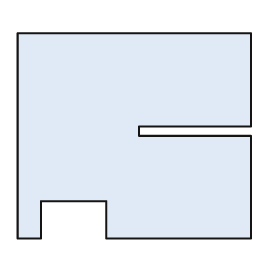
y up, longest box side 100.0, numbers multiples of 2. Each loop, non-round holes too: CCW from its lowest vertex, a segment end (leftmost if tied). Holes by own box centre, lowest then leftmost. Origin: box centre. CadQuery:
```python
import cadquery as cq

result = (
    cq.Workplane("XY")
    .moveTo(-50.0, -44.0)
    .lineTo(-40.0, -44.0)
    .lineTo(-40.0, -28.0)
    .lineTo(-12.0, -28.0)
    .lineTo(-12.0, -44.0)
    .lineTo(50.0, -44.0)
    .lineTo(50.0, 0.0)
    .lineTo(2.0, 0.0)
    .lineTo(2.0, 4.0)
    .lineTo(50.0, 4.0)
    .lineTo(50.0, 44.0)
    .lineTo(-50.0, 44.0)
    .close()
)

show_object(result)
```